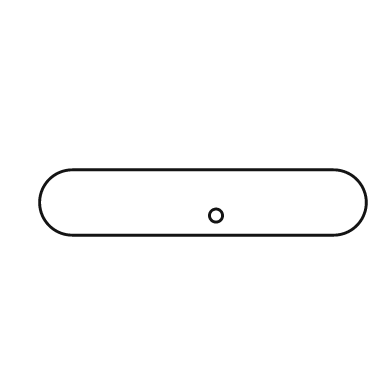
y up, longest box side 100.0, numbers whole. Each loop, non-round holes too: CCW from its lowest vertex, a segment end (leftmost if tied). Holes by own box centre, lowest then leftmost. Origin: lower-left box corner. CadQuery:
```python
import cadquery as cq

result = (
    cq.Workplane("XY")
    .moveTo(10.0, 0.0)
    .lineTo(90.0, 0.0)
    .threePointArc((100.0, 10.0), (90.0, 20.0))
    .lineTo(10.0, 20.0)
    .threePointArc((0.0, 10.0), (10.0, 0.0))
    .close()
    .moveTo(54.0, 6.0)
    .circle(2.0)
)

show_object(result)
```